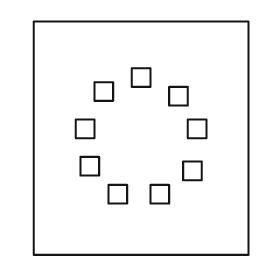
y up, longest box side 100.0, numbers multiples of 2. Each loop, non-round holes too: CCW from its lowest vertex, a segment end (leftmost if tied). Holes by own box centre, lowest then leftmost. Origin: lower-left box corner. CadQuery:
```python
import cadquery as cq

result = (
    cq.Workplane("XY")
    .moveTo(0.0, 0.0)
    .lineTo(92.0, 0.0)
    .lineTo(92.0, 100.0)
    .lineTo(0.0, 100.0)
    .close()
    .moveTo(32.0, 22.0)
    .lineTo(40.0, 22.0)
    .lineTo(40.0, 30.0)
    .lineTo(32.0, 30.0)
    .close()
    .moveTo(50.0, 22.0)
    .lineTo(58.0, 22.0)
    .lineTo(58.0, 30.0)
    .lineTo(50.0, 30.0)
    .close()
    .moveTo(64.0, 32.0)
    .lineTo(72.0, 32.0)
    .lineTo(72.0, 40.0)
    .lineTo(64.0, 40.0)
    .close()
    .moveTo(20.0, 34.0)
    .lineTo(28.0, 34.0)
    .lineTo(28.0, 42.0)
    .lineTo(20.0, 42.0)
    .close()
    .moveTo(18.0, 50.0)
    .lineTo(26.0, 50.0)
    .lineTo(26.0, 58.0)
    .lineTo(18.0, 58.0)
    .close()
    .moveTo(66.0, 50.0)
    .lineTo(74.0, 50.0)
    .lineTo(74.0, 58.0)
    .lineTo(66.0, 58.0)
    .close()
    .moveTo(58.0, 64.0)
    .lineTo(66.0, 64.0)
    .lineTo(66.0, 72.0)
    .lineTo(58.0, 72.0)
    .close()
    .moveTo(26.0, 66.0)
    .lineTo(34.0, 66.0)
    .lineTo(34.0, 74.0)
    .lineTo(26.0, 74.0)
    .close()
    .moveTo(42.0, 72.0)
    .lineTo(50.0, 72.0)
    .lineTo(50.0, 80.0)
    .lineTo(42.0, 80.0)
    .close()
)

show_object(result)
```